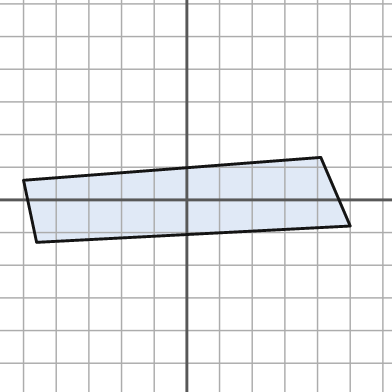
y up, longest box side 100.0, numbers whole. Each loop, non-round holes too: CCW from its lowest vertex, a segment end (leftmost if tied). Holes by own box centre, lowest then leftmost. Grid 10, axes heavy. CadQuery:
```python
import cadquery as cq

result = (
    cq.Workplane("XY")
    .moveTo(-46.0, -13.0)
    .lineTo(50.0, -8.0)
    .lineTo(41.0, 13.0)
    .lineTo(-50.0, 6.0)
    .close()
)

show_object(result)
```